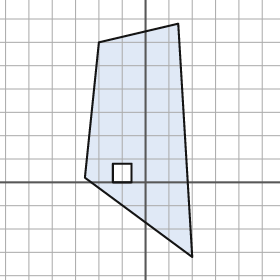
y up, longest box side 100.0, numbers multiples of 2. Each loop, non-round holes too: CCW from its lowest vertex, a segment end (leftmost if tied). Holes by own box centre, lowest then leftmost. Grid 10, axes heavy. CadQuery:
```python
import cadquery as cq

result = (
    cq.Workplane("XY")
    .moveTo(20.0, -32.0)
    .lineTo(14.0, 68.0)
    .lineTo(-20.0, 60.0)
    .lineTo(-26.0, 2.0)
    .close()
    .moveTo(-14.0, 0.0)
    .lineTo(-6.0, 0.0)
    .lineTo(-6.0, 8.0)
    .lineTo(-14.0, 8.0)
    .close()
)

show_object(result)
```